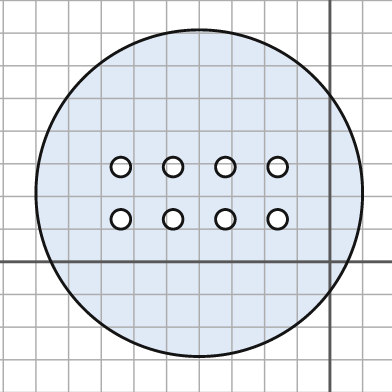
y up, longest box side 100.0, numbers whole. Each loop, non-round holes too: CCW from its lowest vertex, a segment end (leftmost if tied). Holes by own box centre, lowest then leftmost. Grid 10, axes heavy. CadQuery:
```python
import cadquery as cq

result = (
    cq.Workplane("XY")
    .moveTo(-40.0, 21.0)
    .circle(50.0)
    .moveTo(-64.0, 13.0)
    .circle(3.0)
    .moveTo(-48.0, 13.0)
    .circle(3.0)
    .moveTo(-32.0, 13.0)
    .circle(3.0)
    .moveTo(-16.0, 13.0)
    .circle(3.0)
    .moveTo(-64.0, 29.0)
    .circle(3.0)
    .moveTo(-48.0, 29.0)
    .circle(3.0)
    .moveTo(-32.0, 29.0)
    .circle(3.0)
    .moveTo(-16.0, 29.0)
    .circle(3.0)
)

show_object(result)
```